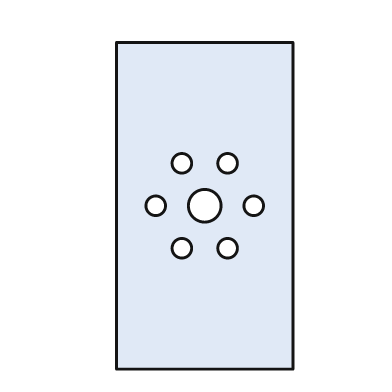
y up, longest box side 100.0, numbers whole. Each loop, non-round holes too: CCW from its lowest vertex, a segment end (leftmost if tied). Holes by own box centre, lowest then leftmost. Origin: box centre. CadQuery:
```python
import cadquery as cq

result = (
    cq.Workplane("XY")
    .moveTo(-27.0, -50.0)
    .lineTo(27.0, -50.0)
    .lineTo(27.0, 50.0)
    .lineTo(-27.0, 50.0)
    .close()
    .moveTo(-7.0, -13.0)
    .circle(3.0)
    .moveTo(7.0, -13.0)
    .circle(3.0)
    .moveTo(-15.0, 0.0)
    .circle(3.0)
    .moveTo(0.0, 0.0)
    .circle(5.0)
    .moveTo(15.0, 0.0)
    .circle(3.0)
    .moveTo(-7.0, 13.0)
    .circle(3.0)
    .moveTo(7.0, 13.0)
    .circle(3.0)
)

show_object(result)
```